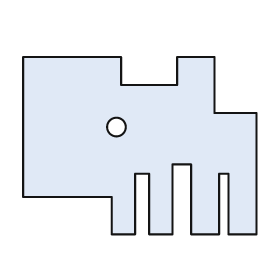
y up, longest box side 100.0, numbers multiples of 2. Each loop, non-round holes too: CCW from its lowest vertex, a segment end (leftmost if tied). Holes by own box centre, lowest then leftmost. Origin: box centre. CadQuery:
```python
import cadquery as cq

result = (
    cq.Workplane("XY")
    .moveTo(-12.0, -38.0)
    .lineTo(-2.0, -38.0)
    .lineTo(-2.0, -12.0)
    .lineTo(4.0, -12.0)
    .lineTo(4.0, -38.0)
    .lineTo(14.0, -38.0)
    .lineTo(14.0, -8.0)
    .lineTo(22.0, -8.0)
    .lineTo(22.0, -38.0)
    .lineTo(34.0, -38.0)
    .lineTo(34.0, -12.0)
    .lineTo(38.0, -12.0)
    .lineTo(38.0, -38.0)
    .lineTo(50.0, -38.0)
    .lineTo(50.0, 14.0)
    .lineTo(32.0, 14.0)
    .lineTo(32.0, 38.0)
    .lineTo(16.0, 38.0)
    .lineTo(16.0, 26.0)
    .lineTo(-8.0, 26.0)
    .lineTo(-8.0, 38.0)
    .lineTo(-50.0, 38.0)
    .lineTo(-50.0, -22.0)
    .lineTo(-12.0, -22.0)
    .close()
    .moveTo(-10.0, 8.0)
    .circle(4.0)
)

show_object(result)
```